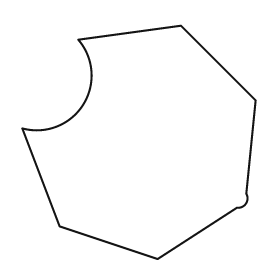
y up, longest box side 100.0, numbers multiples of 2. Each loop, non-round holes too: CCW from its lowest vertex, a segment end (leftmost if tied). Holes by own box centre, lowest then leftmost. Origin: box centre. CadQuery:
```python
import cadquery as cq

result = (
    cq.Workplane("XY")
    .moveTo(8.0, -50.0)
    .lineTo(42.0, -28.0)
    .threePointArc((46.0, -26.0), (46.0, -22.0))
    .lineTo(50.0, 18.0)
    .lineTo(18.0, 50.0)
    .lineTo(-26.0, 44.0)
    .threePointArc((-24.0, 16.0), (-50.0, 6.0))
    .lineTo(-34.0, -36.0)
    .close()
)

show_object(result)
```